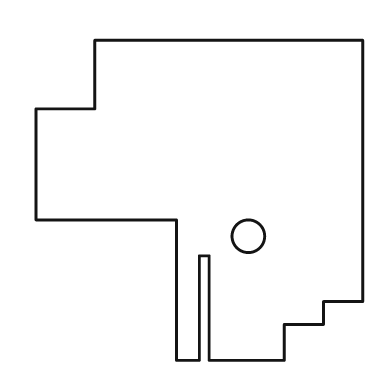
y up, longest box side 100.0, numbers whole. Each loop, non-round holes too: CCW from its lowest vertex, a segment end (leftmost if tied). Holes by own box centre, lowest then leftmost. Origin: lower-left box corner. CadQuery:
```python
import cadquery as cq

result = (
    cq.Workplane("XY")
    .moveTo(43.0, 0.0)
    .lineTo(50.0, 0.0)
    .lineTo(50.0, 32.0)
    .lineTo(53.0, 32.0)
    .lineTo(53.0, 0.0)
    .lineTo(76.0, 0.0)
    .lineTo(76.0, 11.0)
    .lineTo(88.0, 11.0)
    .lineTo(88.0, 18.0)
    .lineTo(100.0, 18.0)
    .lineTo(100.0, 98.0)
    .lineTo(18.0, 98.0)
    .lineTo(18.0, 77.0)
    .lineTo(0.0, 77.0)
    .lineTo(0.0, 43.0)
    .lineTo(43.0, 43.0)
    .close()
    .moveTo(65.0, 38.0)
    .circle(5.0)
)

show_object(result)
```